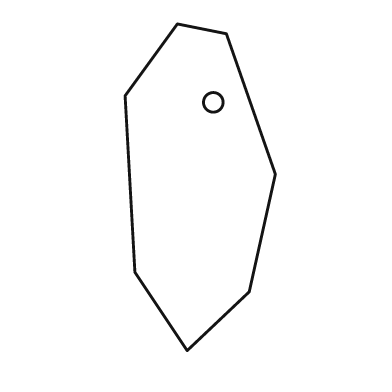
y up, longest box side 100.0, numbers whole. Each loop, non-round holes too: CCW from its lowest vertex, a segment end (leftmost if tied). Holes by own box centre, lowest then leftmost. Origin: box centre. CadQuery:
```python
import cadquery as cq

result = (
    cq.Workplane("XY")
    .moveTo(-4.0, -50.0)
    .lineTo(15.0, -32.0)
    .lineTo(23.0, 4.0)
    .lineTo(8.0, 47.0)
    .lineTo(-7.0, 50.0)
    .lineTo(-23.0, 28.0)
    .lineTo(-20.0, -26.0)
    .close()
    .moveTo(4.0, 26.0)
    .circle(3.0)
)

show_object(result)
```